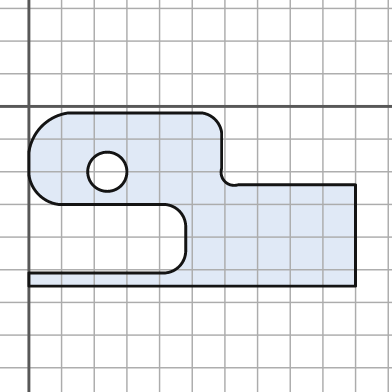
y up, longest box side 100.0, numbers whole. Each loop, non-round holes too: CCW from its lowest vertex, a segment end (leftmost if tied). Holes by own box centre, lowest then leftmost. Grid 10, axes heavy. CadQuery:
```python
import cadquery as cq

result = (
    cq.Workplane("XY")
    .moveTo(0.0, -55.0)
    .lineTo(100.0, -55.0)
    .lineTo(100.0, -24.0)
    .lineTo(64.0, -24.0)
    .threePointArc((60.0, -23.0), (59.0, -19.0))
    .lineTo(59.0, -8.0)
    .threePointArc((57.0, -4.0), (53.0, -2.0))
    .lineTo(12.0, -2.0)
    .threePointArc((4.0, -6.0), (0.0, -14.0))
    .lineTo(0.0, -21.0)
    .threePointArc((3.0, -27.0), (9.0, -30.0))
    .lineTo(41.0, -30.0)
    .threePointArc((46.0, -32.0), (48.0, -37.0))
    .lineTo(48.0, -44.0)
    .threePointArc((46.0, -49.0), (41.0, -51.0))
    .lineTo(0.0, -51.0)
    .close()
    .moveTo(24.0, -20.0)
    .circle(6.0)
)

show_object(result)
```